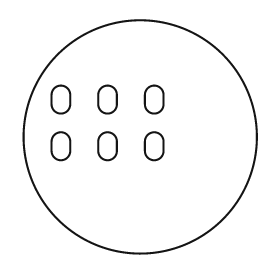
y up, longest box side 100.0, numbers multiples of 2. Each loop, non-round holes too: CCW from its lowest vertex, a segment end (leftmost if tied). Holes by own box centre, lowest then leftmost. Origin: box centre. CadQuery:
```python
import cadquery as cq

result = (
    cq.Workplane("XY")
    .moveTo(0.0, 0.0)
    .circle(50.0)
    .moveTo(-38.0, -6.0)
    .threePointArc((-34.0, -10.0), (-30.0, -6.0))
    .lineTo(-30.0, -2.0)
    .threePointArc((-34.0, 2.0), (-38.0, -2.0))
    .close()
    .moveTo(-18.0, -6.0)
    .threePointArc((-14.0, -10.0), (-10.0, -6.0))
    .lineTo(-10.0, -2.0)
    .threePointArc((-14.0, 2.0), (-18.0, -2.0))
    .close()
    .moveTo(2.0, -6.0)
    .threePointArc((6.0, -10.0), (10.0, -6.0))
    .lineTo(10.0, -2.0)
    .threePointArc((6.0, 2.0), (2.0, -2.0))
    .close()
    .moveTo(-38.0, 14.0)
    .threePointArc((-34.0, 10.0), (-30.0, 14.0))
    .lineTo(-30.0, 18.0)
    .threePointArc((-34.0, 22.0), (-38.0, 18.0))
    .close()
    .moveTo(-18.0, 14.0)
    .threePointArc((-14.0, 10.0), (-10.0, 14.0))
    .lineTo(-10.0, 18.0)
    .threePointArc((-14.0, 22.0), (-18.0, 18.0))
    .close()
    .moveTo(2.0, 14.0)
    .threePointArc((6.0, 10.0), (10.0, 14.0))
    .lineTo(10.0, 18.0)
    .threePointArc((6.0, 22.0), (2.0, 18.0))
    .close()
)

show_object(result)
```